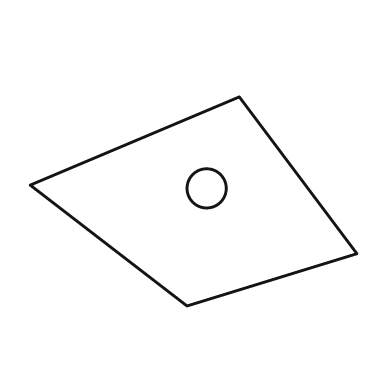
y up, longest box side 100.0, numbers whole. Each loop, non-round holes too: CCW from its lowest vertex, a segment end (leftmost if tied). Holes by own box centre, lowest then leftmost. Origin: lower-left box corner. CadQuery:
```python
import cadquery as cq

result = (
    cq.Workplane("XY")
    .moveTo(48.0, 0.0)
    .lineTo(100.0, 16.0)
    .lineTo(64.0, 64.0)
    .lineTo(0.0, 37.0)
    .close()
    .moveTo(54.0, 36.0)
    .circle(6.0)
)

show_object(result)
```